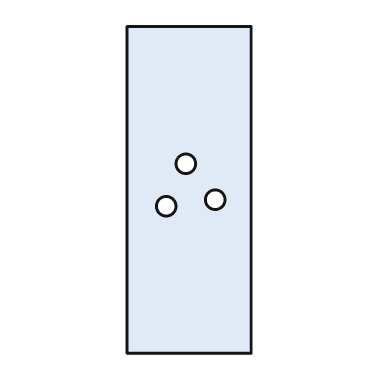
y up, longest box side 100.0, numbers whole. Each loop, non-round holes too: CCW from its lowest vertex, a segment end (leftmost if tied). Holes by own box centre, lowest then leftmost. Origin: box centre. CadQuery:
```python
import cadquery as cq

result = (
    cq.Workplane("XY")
    .moveTo(-19.0, -50.0)
    .lineTo(19.0, -50.0)
    .lineTo(19.0, 50.0)
    .lineTo(-19.0, 50.0)
    .close()
    .moveTo(-7.0, -5.0)
    .circle(3.0)
    .moveTo(8.0, -3.0)
    .circle(3.0)
    .moveTo(-1.0, 8.0)
    .circle(3.0)
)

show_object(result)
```